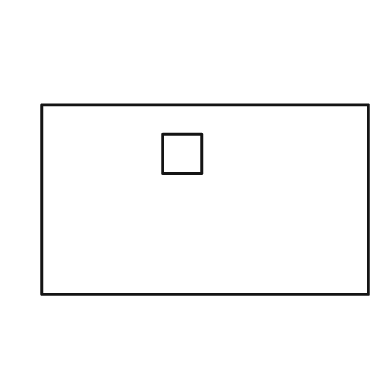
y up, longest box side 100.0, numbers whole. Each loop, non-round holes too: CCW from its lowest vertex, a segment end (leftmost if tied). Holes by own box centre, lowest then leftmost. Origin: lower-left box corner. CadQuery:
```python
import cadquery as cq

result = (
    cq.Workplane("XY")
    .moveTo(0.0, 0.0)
    .lineTo(100.0, 0.0)
    .lineTo(100.0, 58.0)
    .lineTo(0.0, 58.0)
    .close()
    .moveTo(37.0, 37.0)
    .lineTo(49.0, 37.0)
    .lineTo(49.0, 49.0)
    .lineTo(37.0, 49.0)
    .close()
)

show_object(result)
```